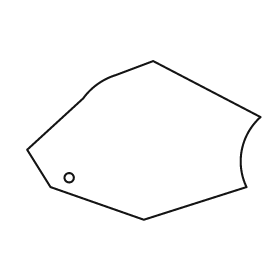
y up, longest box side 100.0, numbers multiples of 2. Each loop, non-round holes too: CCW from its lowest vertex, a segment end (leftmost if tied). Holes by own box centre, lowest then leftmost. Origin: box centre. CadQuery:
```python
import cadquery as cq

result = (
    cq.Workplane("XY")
    .moveTo(0.0, -34.0)
    .lineTo(44.0, -20.0)
    .threePointArc((42.0, -4.0), (50.0, 10.0))
    .lineTo(4.0, 34.0)
    .lineTo(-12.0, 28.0)
    .threePointArc((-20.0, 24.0), (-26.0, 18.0))
    .lineTo(-50.0, -4.0)
    .lineTo(-40.0, -20.0)
    .close()
    .moveTo(-32.0, -16.0)
    .circle(2.0)
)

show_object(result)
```